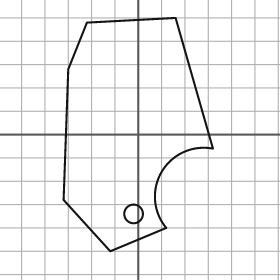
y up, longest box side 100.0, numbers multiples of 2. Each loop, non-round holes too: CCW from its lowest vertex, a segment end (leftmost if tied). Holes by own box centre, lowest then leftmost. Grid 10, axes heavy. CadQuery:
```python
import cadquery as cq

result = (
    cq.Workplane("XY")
    .moveTo(-12.0, -50.0)
    .lineTo(12.0, -40.0)
    .threePointArc((10.0, -16.0), (32.0, -6.0))
    .lineTo(16.0, 50.0)
    .lineTo(-22.0, 48.0)
    .lineTo(-30.0, 28.0)
    .lineTo(-32.0, -28.0)
    .close()
    .moveTo(-2.0, -34.0)
    .circle(4.0)
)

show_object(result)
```